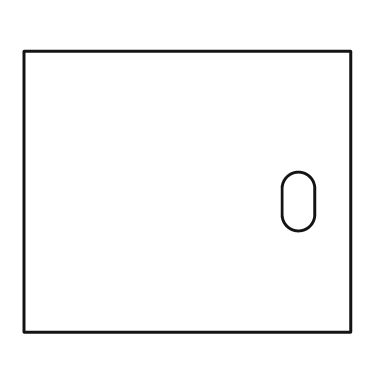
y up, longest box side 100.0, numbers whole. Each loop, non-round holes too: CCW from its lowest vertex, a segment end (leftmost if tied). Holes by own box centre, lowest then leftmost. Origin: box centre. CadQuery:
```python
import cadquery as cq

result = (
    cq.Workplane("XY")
    .moveTo(-50.0, -43.0)
    .lineTo(50.0, -43.0)
    .lineTo(50.0, 43.0)
    .lineTo(-50.0, 43.0)
    .close()
    .moveTo(29.0, -7.0)
    .threePointArc((34.0, -12.0), (39.0, -7.0))
    .lineTo(39.0, 1.0)
    .threePointArc((34.0, 6.0), (29.0, 1.0))
    .close()
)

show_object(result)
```